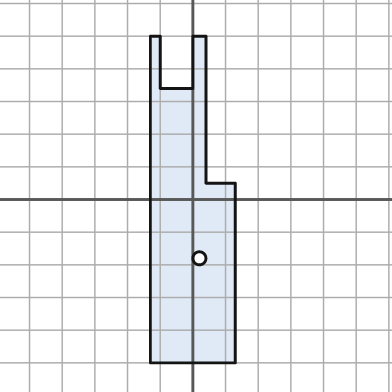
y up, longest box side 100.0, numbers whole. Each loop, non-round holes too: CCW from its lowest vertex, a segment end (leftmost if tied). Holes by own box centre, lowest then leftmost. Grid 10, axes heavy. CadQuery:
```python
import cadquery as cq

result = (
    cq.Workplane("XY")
    .moveTo(-13.0, -50.0)
    .lineTo(13.0, -50.0)
    .lineTo(13.0, 5.0)
    .lineTo(4.0, 5.0)
    .lineTo(4.0, 50.0)
    .lineTo(0.0, 50.0)
    .lineTo(0.0, 34.0)
    .lineTo(-10.0, 34.0)
    .lineTo(-10.0, 50.0)
    .lineTo(-13.0, 50.0)
    .close()
    .moveTo(2.0, -18.0)
    .circle(2.0)
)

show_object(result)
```